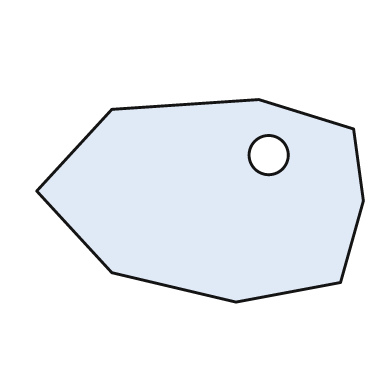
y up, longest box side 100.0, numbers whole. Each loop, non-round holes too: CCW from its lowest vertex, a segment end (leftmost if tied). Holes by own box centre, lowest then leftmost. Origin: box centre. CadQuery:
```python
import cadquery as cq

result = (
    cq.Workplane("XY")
    .moveTo(11.0, -31.0)
    .lineTo(43.0, -25.0)
    .lineTo(50.0, 0.0)
    .lineTo(47.0, 22.0)
    .lineTo(18.0, 31.0)
    .lineTo(-27.0, 28.0)
    .lineTo(-50.0, 3.0)
    .lineTo(-27.0, -22.0)
    .close()
    .moveTo(21.0, 14.0)
    .circle(6.0)
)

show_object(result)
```